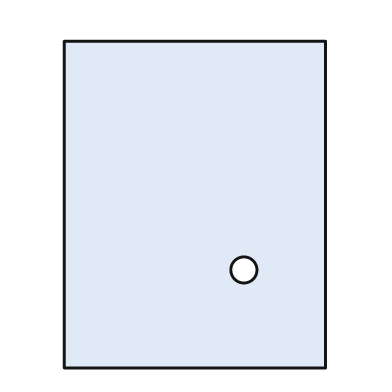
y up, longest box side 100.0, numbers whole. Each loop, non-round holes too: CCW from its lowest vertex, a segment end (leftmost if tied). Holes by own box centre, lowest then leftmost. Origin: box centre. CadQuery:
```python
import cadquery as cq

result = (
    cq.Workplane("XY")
    .moveTo(-40.0, -50.0)
    .lineTo(40.0, -50.0)
    .lineTo(40.0, 50.0)
    .lineTo(-40.0, 50.0)
    .close()
    .moveTo(15.0, -20.0)
    .circle(4.0)
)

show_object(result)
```